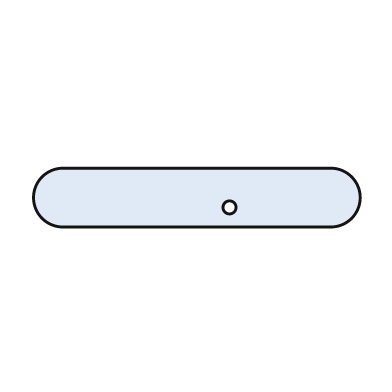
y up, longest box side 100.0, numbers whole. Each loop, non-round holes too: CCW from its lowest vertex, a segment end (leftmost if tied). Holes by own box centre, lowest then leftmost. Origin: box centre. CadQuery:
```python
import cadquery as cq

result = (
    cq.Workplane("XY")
    .moveTo(-41.0, -9.0)
    .lineTo(41.0, -9.0)
    .threePointArc((50.0, 0.0), (41.0, 9.0))
    .lineTo(-41.0, 9.0)
    .threePointArc((-50.0, 0.0), (-41.0, -9.0))
    .close()
    .moveTo(10.0, -3.0)
    .circle(2.0)
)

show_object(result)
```